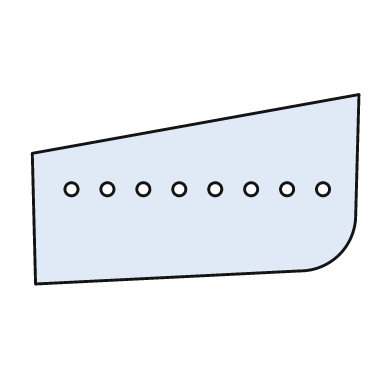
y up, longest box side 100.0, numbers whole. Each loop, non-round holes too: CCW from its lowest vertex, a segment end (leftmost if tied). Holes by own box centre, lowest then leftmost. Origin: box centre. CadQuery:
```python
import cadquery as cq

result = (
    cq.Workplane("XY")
    .moveTo(-49.0, -29.0)
    .lineTo(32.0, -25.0)
    .threePointArc((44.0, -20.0), (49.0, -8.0))
    .lineTo(50.0, 29.0)
    .lineTo(-50.0, 11.0)
    .close()
    .moveTo(-38.0, 0.0)
    .circle(2.0)
    .moveTo(-27.0, 0.0)
    .circle(2.0)
    .moveTo(-16.0, 0.0)
    .circle(2.0)
    .moveTo(-5.0, 0.0)
    .circle(2.0)
    .moveTo(6.0, 0.0)
    .circle(2.0)
    .moveTo(17.0, 0.0)
    .circle(2.0)
    .moveTo(28.0, 0.0)
    .circle(2.0)
    .moveTo(39.0, 0.0)
    .circle(2.0)
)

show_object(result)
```